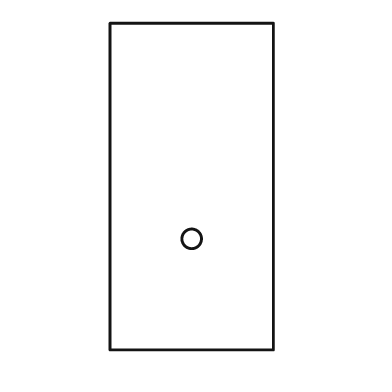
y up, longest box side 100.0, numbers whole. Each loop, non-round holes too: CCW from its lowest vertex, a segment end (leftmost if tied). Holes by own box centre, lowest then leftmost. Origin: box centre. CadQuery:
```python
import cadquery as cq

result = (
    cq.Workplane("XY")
    .moveTo(-25.0, -50.0)
    .lineTo(25.0, -50.0)
    .lineTo(25.0, 50.0)
    .lineTo(-25.0, 50.0)
    .close()
    .moveTo(0.0, -16.0)
    .circle(3.0)
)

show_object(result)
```